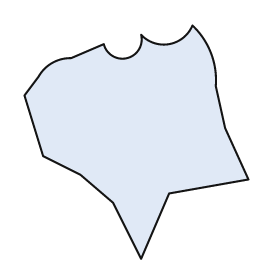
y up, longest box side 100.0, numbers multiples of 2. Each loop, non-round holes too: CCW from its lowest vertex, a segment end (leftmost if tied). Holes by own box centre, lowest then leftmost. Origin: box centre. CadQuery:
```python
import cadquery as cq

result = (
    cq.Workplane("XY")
    .moveTo(2.0, -50.0)
    .lineTo(14.0, -22.0)
    .lineTo(48.0, -16.0)
    .lineTo(38.0, 6.0)
    .lineTo(34.0, 24.0)
    .threePointArc((32.0, 38.0), (24.0, 50.0))
    .threePointArc((14.0, 42.0), (2.0, 46.0))
    .threePointArc((-4.0, 36.0), (-14.0, 42.0))
    .lineTo(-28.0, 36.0)
    .threePointArc((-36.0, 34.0), (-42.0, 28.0))
    .lineTo(-48.0, 20.0)
    .lineTo(-40.0, -6.0)
    .lineTo(-24.0, -14.0)
    .lineTo(-10.0, -26.0)
    .close()
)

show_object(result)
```